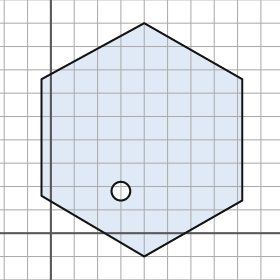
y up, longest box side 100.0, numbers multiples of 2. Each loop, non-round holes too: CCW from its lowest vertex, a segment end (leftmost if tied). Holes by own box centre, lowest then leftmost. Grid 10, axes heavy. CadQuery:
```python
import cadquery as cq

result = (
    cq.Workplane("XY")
    .moveTo(40.0, -10.0)
    .lineTo(82.0, 14.0)
    .lineTo(82.0, 66.0)
    .lineTo(40.0, 90.0)
    .lineTo(-4.0, 66.0)
    .lineTo(-4.0, 16.0)
    .close()
    .moveTo(30.0, 18.0)
    .circle(4.0)
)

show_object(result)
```